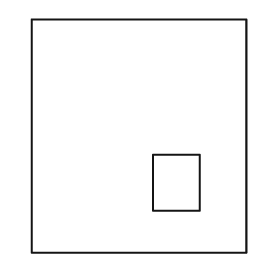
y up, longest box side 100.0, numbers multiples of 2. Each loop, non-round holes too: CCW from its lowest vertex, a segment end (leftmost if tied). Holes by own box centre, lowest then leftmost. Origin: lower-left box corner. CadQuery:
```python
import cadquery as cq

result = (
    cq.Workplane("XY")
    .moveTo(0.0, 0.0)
    .lineTo(92.0, 0.0)
    .lineTo(92.0, 100.0)
    .lineTo(0.0, 100.0)
    .close()
    .moveTo(52.0, 18.0)
    .lineTo(72.0, 18.0)
    .lineTo(72.0, 42.0)
    .lineTo(52.0, 42.0)
    .close()
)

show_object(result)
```